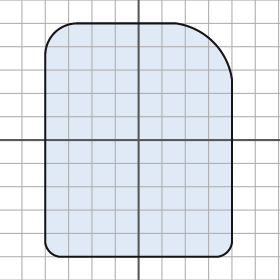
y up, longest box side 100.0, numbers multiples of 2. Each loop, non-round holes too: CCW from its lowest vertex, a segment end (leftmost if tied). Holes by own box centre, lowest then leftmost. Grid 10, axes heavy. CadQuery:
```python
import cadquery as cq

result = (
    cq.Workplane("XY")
    .moveTo(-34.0, -50.0)
    .lineTo(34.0, -50.0)
    .threePointArc((38.0, -48.0), (40.0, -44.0))
    .lineTo(40.0, 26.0)
    .threePointArc((32.0, 42.0), (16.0, 50.0))
    .lineTo(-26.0, 50.0)
    .threePointArc((-36.0, 46.0), (-40.0, 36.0))
    .lineTo(-40.0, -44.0)
    .threePointArc((-38.0, -48.0), (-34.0, -50.0))
    .close()
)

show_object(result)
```